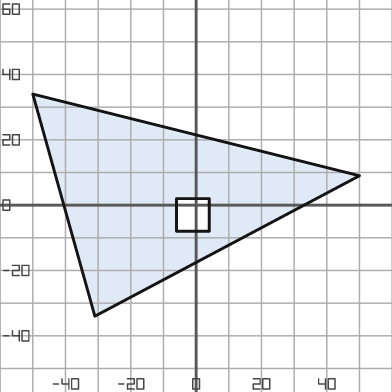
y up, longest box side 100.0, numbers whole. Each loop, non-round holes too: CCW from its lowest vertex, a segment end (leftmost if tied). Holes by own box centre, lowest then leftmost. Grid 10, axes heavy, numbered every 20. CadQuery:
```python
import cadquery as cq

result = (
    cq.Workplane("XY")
    .moveTo(-31.0, -34.0)
    .lineTo(50.0, 9.0)
    .lineTo(-50.0, 34.0)
    .close()
    .moveTo(-6.0, -8.0)
    .lineTo(4.0, -8.0)
    .lineTo(4.0, 2.0)
    .lineTo(-6.0, 2.0)
    .close()
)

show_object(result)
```